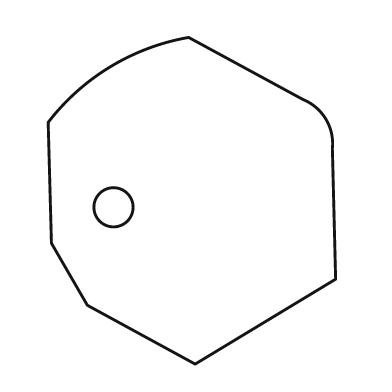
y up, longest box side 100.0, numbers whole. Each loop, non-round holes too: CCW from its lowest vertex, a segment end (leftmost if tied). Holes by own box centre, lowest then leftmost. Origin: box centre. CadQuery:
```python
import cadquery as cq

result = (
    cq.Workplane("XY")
    .moveTo(1.0, -50.0)
    .lineTo(44.0, -24.0)
    .lineTo(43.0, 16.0)
    .threePointArc((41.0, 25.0), (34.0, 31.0))
    .lineTo(-1.0, 50.0)
    .threePointArc((-25.0, 41.0), (-44.0, 24.0))
    .lineTo(-43.0, -13.0)
    .lineTo(-32.0, -32.0)
    .close()
    .moveTo(-24.0, -2.0)
    .circle(6.0)
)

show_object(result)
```